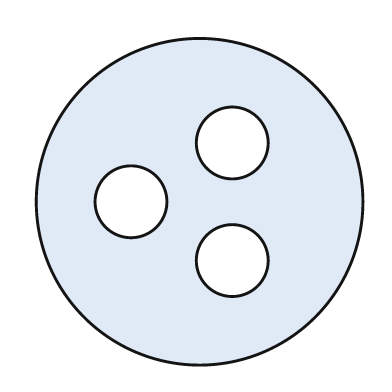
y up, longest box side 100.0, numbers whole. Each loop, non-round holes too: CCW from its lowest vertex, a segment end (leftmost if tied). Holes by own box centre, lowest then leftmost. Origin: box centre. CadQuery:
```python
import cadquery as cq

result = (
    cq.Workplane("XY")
    .moveTo(0.0, 0.0)
    .circle(50.0)
    .moveTo(10.0, -18.0)
    .circle(11.0)
    .moveTo(-21.0, 0.0)
    .circle(11.0)
    .moveTo(10.0, 18.0)
    .circle(11.0)
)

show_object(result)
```